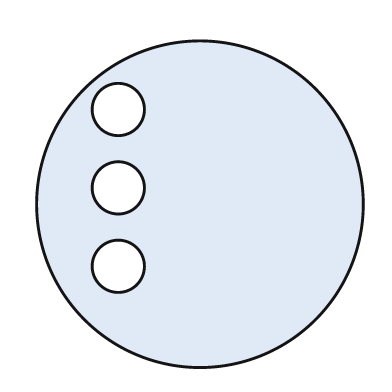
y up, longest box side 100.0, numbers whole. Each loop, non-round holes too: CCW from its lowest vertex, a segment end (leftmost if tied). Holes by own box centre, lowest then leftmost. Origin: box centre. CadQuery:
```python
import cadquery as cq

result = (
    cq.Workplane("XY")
    .moveTo(0.0, 0.0)
    .circle(50.0)
    .moveTo(-25.0, -19.0)
    .circle(8.0)
    .moveTo(-25.0, 5.0)
    .circle(8.0)
    .moveTo(-25.0, 29.0)
    .circle(8.0)
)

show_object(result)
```